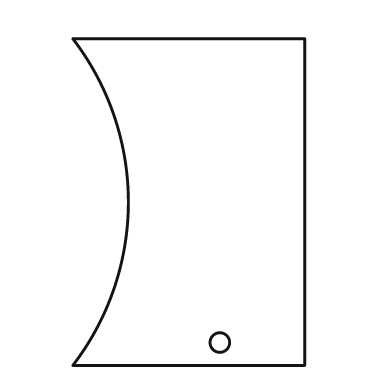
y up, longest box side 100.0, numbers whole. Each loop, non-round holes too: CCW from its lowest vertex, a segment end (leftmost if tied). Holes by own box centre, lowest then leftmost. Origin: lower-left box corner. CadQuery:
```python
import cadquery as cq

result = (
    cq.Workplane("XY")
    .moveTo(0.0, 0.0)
    .lineTo(71.0, 0.0)
    .lineTo(71.0, 100.0)
    .lineTo(0.0, 100.0)
    .threePointArc((17.0, 50.0), (0.0, 0.0))
    .close()
    .moveTo(45.0, 7.0)
    .circle(3.0)
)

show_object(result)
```